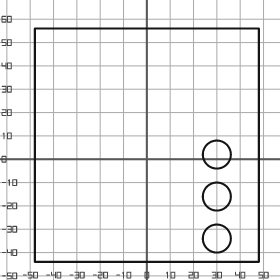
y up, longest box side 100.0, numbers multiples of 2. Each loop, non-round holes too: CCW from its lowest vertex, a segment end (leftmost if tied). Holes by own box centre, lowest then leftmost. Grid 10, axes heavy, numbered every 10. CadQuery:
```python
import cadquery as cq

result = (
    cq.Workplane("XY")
    .moveTo(-48.0, -44.0)
    .lineTo(48.0, -44.0)
    .lineTo(48.0, 56.0)
    .lineTo(-48.0, 56.0)
    .close()
    .moveTo(30.0, -34.0)
    .circle(6.0)
    .moveTo(30.0, -16.0)
    .circle(6.0)
    .moveTo(30.0, 2.0)
    .circle(6.0)
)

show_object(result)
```